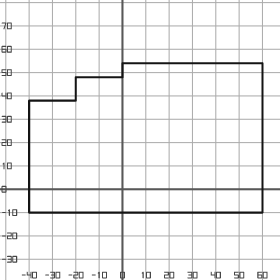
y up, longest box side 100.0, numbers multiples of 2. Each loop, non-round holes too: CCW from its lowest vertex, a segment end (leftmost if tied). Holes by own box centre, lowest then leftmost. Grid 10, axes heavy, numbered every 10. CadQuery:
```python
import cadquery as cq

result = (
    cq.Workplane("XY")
    .moveTo(-40.0, -10.0)
    .lineTo(60.0, -10.0)
    .lineTo(60.0, 54.0)
    .lineTo(0.0, 54.0)
    .lineTo(0.0, 48.0)
    .lineTo(-20.0, 48.0)
    .lineTo(-20.0, 38.0)
    .lineTo(-40.0, 38.0)
    .close()
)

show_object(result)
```